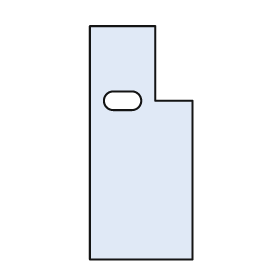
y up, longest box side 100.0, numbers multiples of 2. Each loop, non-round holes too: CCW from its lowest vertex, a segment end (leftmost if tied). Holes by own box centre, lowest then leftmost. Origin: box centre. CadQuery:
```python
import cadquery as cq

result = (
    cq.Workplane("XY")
    .moveTo(-22.0, -50.0)
    .lineTo(22.0, -50.0)
    .lineTo(22.0, 18.0)
    .lineTo(6.0, 18.0)
    .lineTo(6.0, 50.0)
    .lineTo(-22.0, 50.0)
    .close()
    .moveTo(-12.0, 14.0)
    .lineTo(-4.0, 14.0)
    .threePointArc((0.0, 18.0), (-4.0, 22.0))
    .lineTo(-12.0, 22.0)
    .threePointArc((-16.0, 18.0), (-12.0, 14.0))
    .close()
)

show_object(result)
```